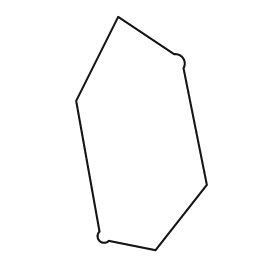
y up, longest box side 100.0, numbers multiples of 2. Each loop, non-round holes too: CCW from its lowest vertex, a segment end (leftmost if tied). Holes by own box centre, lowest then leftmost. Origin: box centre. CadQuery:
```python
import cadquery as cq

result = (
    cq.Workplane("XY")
    .moveTo(6.0, -50.0)
    .lineTo(28.0, -22.0)
    .lineTo(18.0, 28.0)
    .threePointArc((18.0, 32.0), (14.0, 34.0))
    .lineTo(-10.0, 50.0)
    .lineTo(-28.0, 14.0)
    .lineTo(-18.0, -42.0)
    .threePointArc((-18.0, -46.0), (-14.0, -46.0))
    .close()
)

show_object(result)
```